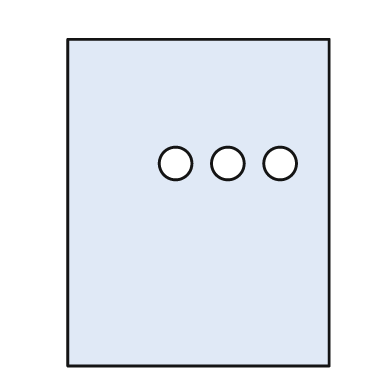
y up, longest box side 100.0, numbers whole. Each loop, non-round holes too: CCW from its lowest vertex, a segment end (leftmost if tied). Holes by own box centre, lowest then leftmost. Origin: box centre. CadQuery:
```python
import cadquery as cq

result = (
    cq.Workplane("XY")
    .moveTo(-40.0, -50.0)
    .lineTo(40.0, -50.0)
    .lineTo(40.0, 50.0)
    .lineTo(-40.0, 50.0)
    .close()
    .moveTo(-7.0, 12.0)
    .circle(5.0)
    .moveTo(9.0, 12.0)
    .circle(5.0)
    .moveTo(25.0, 12.0)
    .circle(5.0)
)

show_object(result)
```